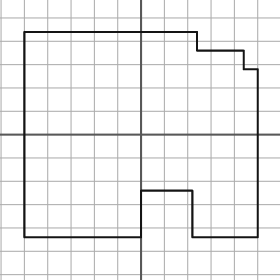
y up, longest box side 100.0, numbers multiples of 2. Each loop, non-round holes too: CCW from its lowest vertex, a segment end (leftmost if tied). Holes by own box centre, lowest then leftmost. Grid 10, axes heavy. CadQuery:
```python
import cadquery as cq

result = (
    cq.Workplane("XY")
    .moveTo(-50.0, -44.0)
    .lineTo(0.0, -44.0)
    .lineTo(0.0, -24.0)
    .lineTo(22.0, -24.0)
    .lineTo(22.0, -44.0)
    .lineTo(50.0, -44.0)
    .lineTo(50.0, 28.0)
    .lineTo(44.0, 28.0)
    .lineTo(44.0, 36.0)
    .lineTo(24.0, 36.0)
    .lineTo(24.0, 44.0)
    .lineTo(-50.0, 44.0)
    .close()
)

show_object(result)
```